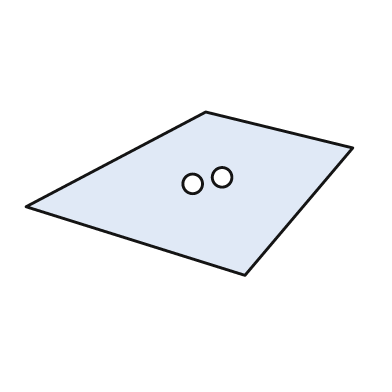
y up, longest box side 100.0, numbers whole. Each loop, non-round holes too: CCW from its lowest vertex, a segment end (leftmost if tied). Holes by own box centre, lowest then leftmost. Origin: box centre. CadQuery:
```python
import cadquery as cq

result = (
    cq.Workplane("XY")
    .moveTo(17.0, -25.0)
    .lineTo(50.0, 14.0)
    .lineTo(5.0, 25.0)
    .lineTo(-50.0, -4.0)
    .close()
    .moveTo(1.0, 3.0)
    .circle(3.0)
    .moveTo(10.0, 5.0)
    .circle(3.0)
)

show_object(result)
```